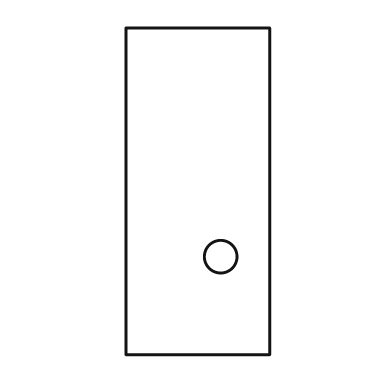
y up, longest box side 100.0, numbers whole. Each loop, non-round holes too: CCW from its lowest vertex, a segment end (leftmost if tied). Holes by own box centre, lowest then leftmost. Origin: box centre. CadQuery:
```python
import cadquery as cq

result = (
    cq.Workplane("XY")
    .moveTo(-22.0, -50.0)
    .lineTo(22.0, -50.0)
    .lineTo(22.0, 50.0)
    .lineTo(-22.0, 50.0)
    .close()
    .moveTo(7.0, -20.0)
    .circle(5.0)
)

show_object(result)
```